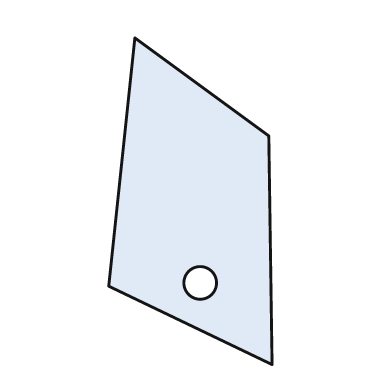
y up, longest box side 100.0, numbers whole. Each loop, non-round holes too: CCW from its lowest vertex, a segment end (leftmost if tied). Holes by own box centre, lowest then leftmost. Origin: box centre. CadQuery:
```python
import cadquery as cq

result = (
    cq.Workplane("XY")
    .moveTo(25.0, -50.0)
    .lineTo(24.0, 20.0)
    .lineTo(-17.0, 50.0)
    .lineTo(-25.0, -26.0)
    .close()
    .moveTo(3.0, -25.0)
    .circle(5.0)
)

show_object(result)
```